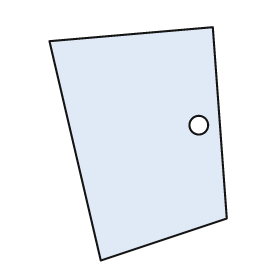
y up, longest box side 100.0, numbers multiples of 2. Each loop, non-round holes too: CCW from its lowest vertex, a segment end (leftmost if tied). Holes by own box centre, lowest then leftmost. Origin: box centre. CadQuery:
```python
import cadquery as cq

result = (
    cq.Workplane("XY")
    .moveTo(-16.0, -50.0)
    .lineTo(38.0, -32.0)
    .lineTo(32.0, 50.0)
    .lineTo(-38.0, 44.0)
    .close()
    .moveTo(26.0, 8.0)
    .circle(4.0)
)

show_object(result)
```